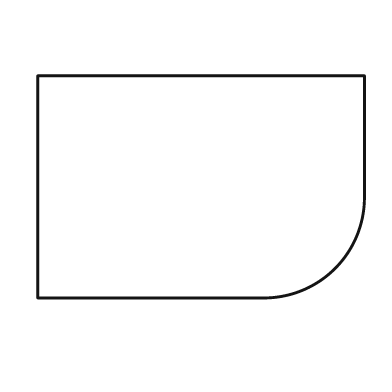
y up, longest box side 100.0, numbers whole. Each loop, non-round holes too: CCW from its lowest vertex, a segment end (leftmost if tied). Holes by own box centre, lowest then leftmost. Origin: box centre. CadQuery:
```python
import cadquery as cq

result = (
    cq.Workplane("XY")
    .moveTo(-50.0, -34.0)
    .lineTo(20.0, -34.0)
    .threePointArc((41.0, -25.0), (50.0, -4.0))
    .lineTo(50.0, 34.0)
    .lineTo(-50.0, 34.0)
    .close()
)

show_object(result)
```